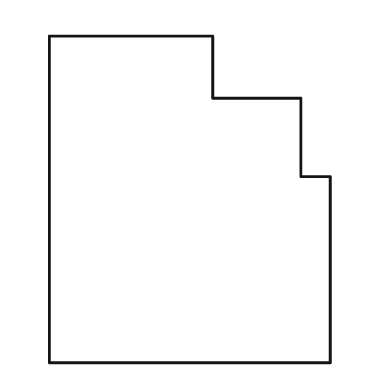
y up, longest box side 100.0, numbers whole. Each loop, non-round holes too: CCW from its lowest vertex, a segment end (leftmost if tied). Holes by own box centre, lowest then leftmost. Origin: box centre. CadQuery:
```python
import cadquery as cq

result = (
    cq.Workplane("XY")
    .moveTo(-43.0, -50.0)
    .lineTo(43.0, -50.0)
    .lineTo(43.0, 7.0)
    .lineTo(34.0, 7.0)
    .lineTo(34.0, 31.0)
    .lineTo(7.0, 31.0)
    .lineTo(7.0, 50.0)
    .lineTo(-43.0, 50.0)
    .close()
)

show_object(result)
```